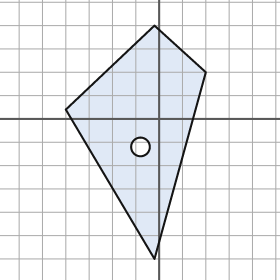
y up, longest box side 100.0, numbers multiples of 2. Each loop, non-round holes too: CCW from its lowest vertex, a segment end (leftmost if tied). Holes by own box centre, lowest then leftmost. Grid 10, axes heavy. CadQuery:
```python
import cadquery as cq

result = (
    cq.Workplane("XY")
    .moveTo(-2.0, -60.0)
    .lineTo(20.0, 20.0)
    .lineTo(-2.0, 40.0)
    .lineTo(-40.0, 4.0)
    .close()
    .moveTo(-8.0, -12.0)
    .circle(4.0)
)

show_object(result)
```